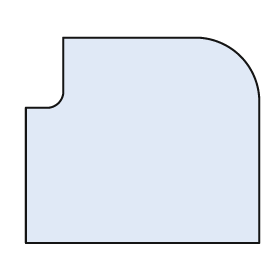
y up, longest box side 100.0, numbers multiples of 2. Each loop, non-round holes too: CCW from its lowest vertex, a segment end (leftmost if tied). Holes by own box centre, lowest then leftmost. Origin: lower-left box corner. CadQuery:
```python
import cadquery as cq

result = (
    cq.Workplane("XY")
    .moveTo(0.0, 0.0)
    .lineTo(100.0, 0.0)
    .lineTo(100.0, 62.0)
    .threePointArc((92.0, 80.0), (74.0, 88.0))
    .lineTo(16.0, 88.0)
    .lineTo(16.0, 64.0)
    .threePointArc((14.0, 60.0), (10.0, 58.0))
    .lineTo(0.0, 58.0)
    .close()
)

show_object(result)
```